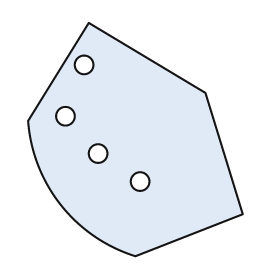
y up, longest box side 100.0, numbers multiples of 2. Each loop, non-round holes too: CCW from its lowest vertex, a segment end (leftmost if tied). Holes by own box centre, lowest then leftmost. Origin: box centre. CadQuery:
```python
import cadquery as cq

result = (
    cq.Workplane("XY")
    .moveTo(0.0, -50.0)
    .lineTo(46.0, -32.0)
    .lineTo(30.0, 20.0)
    .lineTo(-20.0, 50.0)
    .lineTo(-46.0, 8.0)
    .threePointArc((-32.0, -28.0), (0.0, -50.0))
    .close()
    .moveTo(2.0, -18.0)
    .circle(4.0)
    .moveTo(-16.0, -6.0)
    .circle(4.0)
    .moveTo(-30.0, 10.0)
    .circle(4.0)
    .moveTo(-22.0, 32.0)
    .circle(4.0)
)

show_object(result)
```